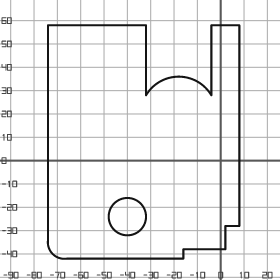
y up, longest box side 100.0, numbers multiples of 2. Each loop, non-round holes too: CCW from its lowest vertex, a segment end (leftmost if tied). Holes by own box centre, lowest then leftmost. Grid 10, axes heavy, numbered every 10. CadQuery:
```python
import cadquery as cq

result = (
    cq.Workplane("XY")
    .moveTo(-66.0, -42.0)
    .lineTo(-16.0, -42.0)
    .lineTo(-16.0, -38.0)
    .lineTo(2.0, -38.0)
    .lineTo(2.0, -28.0)
    .lineTo(8.0, -28.0)
    .lineTo(8.0, 58.0)
    .lineTo(-4.0, 58.0)
    .lineTo(-4.0, 28.0)
    .threePointArc((-18.0, 36.0), (-32.0, 28.0))
    .lineTo(-32.0, 58.0)
    .lineTo(-74.0, 58.0)
    .lineTo(-74.0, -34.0)
    .threePointArc((-72.0, -40.0), (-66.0, -42.0))
    .close()
    .moveTo(-40.0, -24.0)
    .circle(8.0)
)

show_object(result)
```